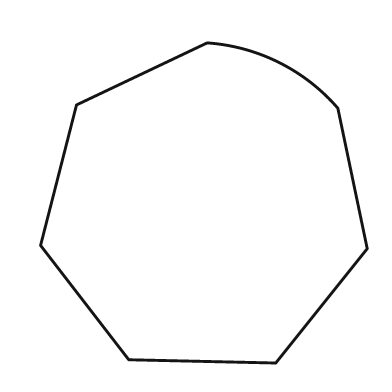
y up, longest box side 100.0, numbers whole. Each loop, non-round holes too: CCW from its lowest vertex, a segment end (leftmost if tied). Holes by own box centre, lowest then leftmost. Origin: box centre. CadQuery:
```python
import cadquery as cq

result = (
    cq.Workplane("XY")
    .moveTo(22.0, -49.0)
    .lineTo(50.0, -14.0)
    .lineTo(41.0, 29.0)
    .threePointArc((23.0, 43.0), (1.0, 49.0))
    .lineTo(-39.0, 30.0)
    .lineTo(-50.0, -13.0)
    .lineTo(-23.0, -48.0)
    .close()
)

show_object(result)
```